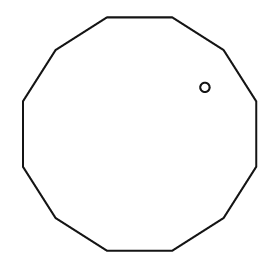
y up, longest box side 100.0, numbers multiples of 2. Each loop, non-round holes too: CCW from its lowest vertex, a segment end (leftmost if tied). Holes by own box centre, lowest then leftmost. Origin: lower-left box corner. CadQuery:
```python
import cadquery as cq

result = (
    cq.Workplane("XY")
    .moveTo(36.0, 0.0)
    .lineTo(64.0, 0.0)
    .lineTo(86.0, 14.0)
    .lineTo(100.0, 36.0)
    .lineTo(100.0, 64.0)
    .lineTo(86.0, 86.0)
    .lineTo(64.0, 100.0)
    .lineTo(36.0, 100.0)
    .lineTo(14.0, 86.0)
    .lineTo(0.0, 64.0)
    .lineTo(0.0, 36.0)
    .lineTo(14.0, 14.0)
    .close()
    .moveTo(78.0, 70.0)
    .circle(2.0)
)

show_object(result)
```